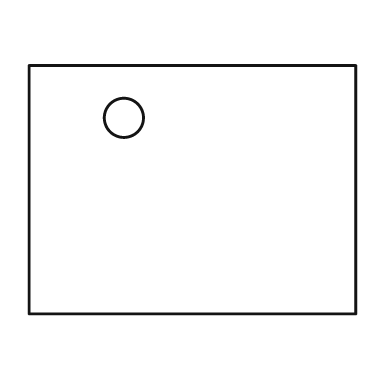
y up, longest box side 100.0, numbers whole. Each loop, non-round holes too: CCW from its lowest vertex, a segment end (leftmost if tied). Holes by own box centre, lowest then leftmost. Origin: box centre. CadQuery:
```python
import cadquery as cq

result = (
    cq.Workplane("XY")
    .moveTo(-50.0, -38.0)
    .lineTo(50.0, -38.0)
    .lineTo(50.0, 38.0)
    .lineTo(-50.0, 38.0)
    .close()
    .moveTo(-21.0, 22.0)
    .circle(6.0)
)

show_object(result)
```